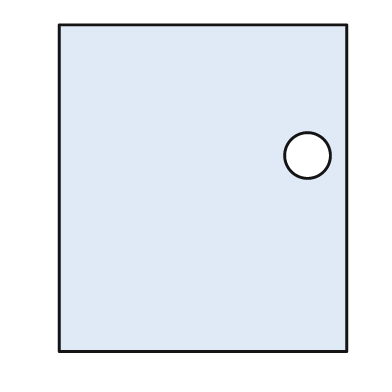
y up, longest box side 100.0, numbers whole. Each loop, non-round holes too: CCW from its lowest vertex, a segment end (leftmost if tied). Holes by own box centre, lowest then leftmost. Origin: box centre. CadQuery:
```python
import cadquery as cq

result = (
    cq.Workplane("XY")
    .moveTo(-44.0, -50.0)
    .lineTo(44.0, -50.0)
    .lineTo(44.0, 50.0)
    .lineTo(-44.0, 50.0)
    .close()
    .moveTo(32.0, 10.0)
    .circle(7.0)
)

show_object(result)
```